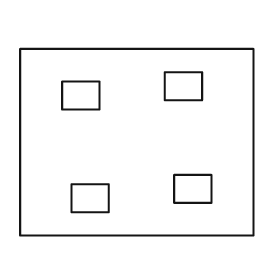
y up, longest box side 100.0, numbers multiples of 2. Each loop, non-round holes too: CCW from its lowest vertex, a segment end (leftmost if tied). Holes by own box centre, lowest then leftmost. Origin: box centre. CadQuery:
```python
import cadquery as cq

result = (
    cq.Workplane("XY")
    .moveTo(-50.0, -40.0)
    .lineTo(50.0, -40.0)
    .lineTo(50.0, 40.0)
    .lineTo(-50.0, 40.0)
    .close()
    .moveTo(-28.0, -30.0)
    .lineTo(-12.0, -30.0)
    .lineTo(-12.0, -18.0)
    .lineTo(-28.0, -18.0)
    .close()
    .moveTo(16.0, -26.0)
    .lineTo(32.0, -26.0)
    .lineTo(32.0, -14.0)
    .lineTo(16.0, -14.0)
    .close()
    .moveTo(-32.0, 14.0)
    .lineTo(-16.0, 14.0)
    .lineTo(-16.0, 26.0)
    .lineTo(-32.0, 26.0)
    .close()
    .moveTo(12.0, 18.0)
    .lineTo(28.0, 18.0)
    .lineTo(28.0, 30.0)
    .lineTo(12.0, 30.0)
    .close()
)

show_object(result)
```